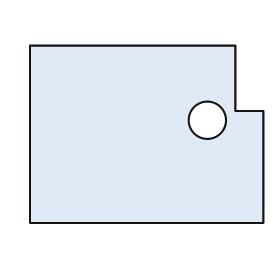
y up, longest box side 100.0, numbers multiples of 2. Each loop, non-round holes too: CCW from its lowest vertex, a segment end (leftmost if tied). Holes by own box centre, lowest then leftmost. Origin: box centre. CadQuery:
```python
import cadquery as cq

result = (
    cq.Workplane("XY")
    .moveTo(-50.0, -38.0)
    .lineTo(50.0, -38.0)
    .lineTo(50.0, 10.0)
    .lineTo(38.0, 10.0)
    .lineTo(38.0, 38.0)
    .lineTo(-50.0, 38.0)
    .close()
    .moveTo(26.0, 6.0)
    .circle(8.0)
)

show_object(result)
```